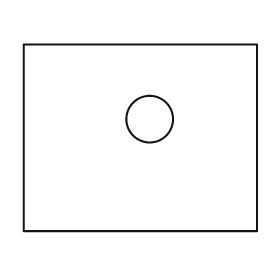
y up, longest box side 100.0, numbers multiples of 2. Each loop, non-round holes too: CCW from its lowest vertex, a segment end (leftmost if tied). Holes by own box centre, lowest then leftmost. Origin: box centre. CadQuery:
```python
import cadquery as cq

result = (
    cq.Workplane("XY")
    .moveTo(-50.0, -40.0)
    .lineTo(50.0, -40.0)
    .lineTo(50.0, 40.0)
    .lineTo(-50.0, 40.0)
    .close()
    .moveTo(4.0, 8.0)
    .circle(10.0)
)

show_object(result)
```